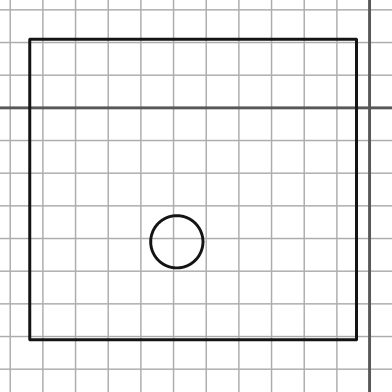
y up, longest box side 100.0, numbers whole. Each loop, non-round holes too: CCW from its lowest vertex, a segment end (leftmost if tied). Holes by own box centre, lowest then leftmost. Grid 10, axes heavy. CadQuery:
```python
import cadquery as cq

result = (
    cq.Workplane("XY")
    .moveTo(-104.0, -71.0)
    .lineTo(-4.0, -71.0)
    .lineTo(-4.0, 21.0)
    .lineTo(-104.0, 21.0)
    .close()
    .moveTo(-59.0, -41.0)
    .circle(8.0)
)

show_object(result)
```